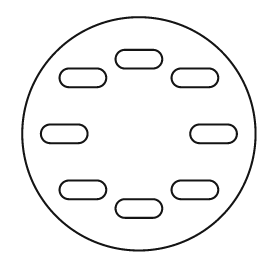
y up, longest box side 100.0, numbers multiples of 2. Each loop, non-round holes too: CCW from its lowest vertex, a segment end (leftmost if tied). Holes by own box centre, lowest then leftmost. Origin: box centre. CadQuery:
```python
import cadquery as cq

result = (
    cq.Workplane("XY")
    .moveTo(0.0, 0.0)
    .circle(50.0)
    .moveTo(-6.0, -36.0)
    .lineTo(6.0, -36.0)
    .threePointArc((10.0, -32.0), (6.0, -28.0))
    .lineTo(-6.0, -28.0)
    .threePointArc((-10.0, -32.0), (-6.0, -36.0))
    .close()
    .moveTo(-30.0, -28.0)
    .lineTo(-18.0, -28.0)
    .threePointArc((-14.0, -24.0), (-18.0, -20.0))
    .lineTo(-30.0, -20.0)
    .threePointArc((-34.0, -24.0), (-30.0, -28.0))
    .close()
    .moveTo(18.0, -28.0)
    .lineTo(30.0, -28.0)
    .threePointArc((34.0, -24.0), (30.0, -20.0))
    .lineTo(18.0, -20.0)
    .threePointArc((14.0, -24.0), (18.0, -28.0))
    .close()
    .moveTo(-38.0, -4.0)
    .lineTo(-26.0, -4.0)
    .threePointArc((-22.0, 0.0), (-26.0, 4.0))
    .lineTo(-38.0, 4.0)
    .threePointArc((-42.0, 0.0), (-38.0, -4.0))
    .close()
    .moveTo(26.0, -4.0)
    .lineTo(38.0, -4.0)
    .threePointArc((42.0, 0.0), (38.0, 4.0))
    .lineTo(26.0, 4.0)
    .threePointArc((22.0, 0.0), (26.0, -4.0))
    .close()
    .moveTo(-30.0, 20.0)
    .lineTo(-18.0, 20.0)
    .threePointArc((-14.0, 24.0), (-18.0, 28.0))
    .lineTo(-30.0, 28.0)
    .threePointArc((-34.0, 24.0), (-30.0, 20.0))
    .close()
    .moveTo(18.0, 20.0)
    .lineTo(30.0, 20.0)
    .threePointArc((34.0, 24.0), (30.0, 28.0))
    .lineTo(18.0, 28.0)
    .threePointArc((14.0, 24.0), (18.0, 20.0))
    .close()
    .moveTo(-6.0, 28.0)
    .lineTo(6.0, 28.0)
    .threePointArc((10.0, 32.0), (6.0, 36.0))
    .lineTo(-6.0, 36.0)
    .threePointArc((-10.0, 32.0), (-6.0, 28.0))
    .close()
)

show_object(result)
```